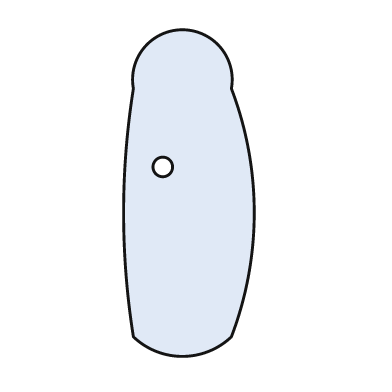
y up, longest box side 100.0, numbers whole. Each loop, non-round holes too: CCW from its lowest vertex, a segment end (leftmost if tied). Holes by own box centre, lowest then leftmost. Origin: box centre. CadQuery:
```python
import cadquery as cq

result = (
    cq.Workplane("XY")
    .moveTo(-17.0, -44.0)
    .threePointArc((-2.0, -50.0), (13.0, -44.0))
    .threePointArc((20.0, -6.0), (13.0, 32.0))
    .threePointArc((-2.0, 50.0), (-17.0, 32.0))
    .threePointArc((-20.0, -6.0), (-17.0, -44.0))
    .close()
    .moveTo(-8.0, 8.0)
    .circle(3.0)
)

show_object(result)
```